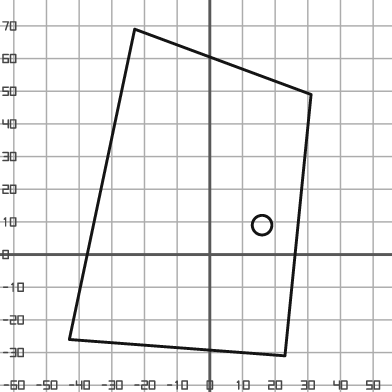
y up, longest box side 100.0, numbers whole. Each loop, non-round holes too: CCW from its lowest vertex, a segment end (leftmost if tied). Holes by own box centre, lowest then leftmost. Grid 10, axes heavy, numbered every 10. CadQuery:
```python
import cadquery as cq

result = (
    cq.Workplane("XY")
    .moveTo(23.0, -31.0)
    .lineTo(31.0, 49.0)
    .lineTo(-23.0, 69.0)
    .lineTo(-43.0, -26.0)
    .close()
    .moveTo(16.0, 9.0)
    .circle(3.0)
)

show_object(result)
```